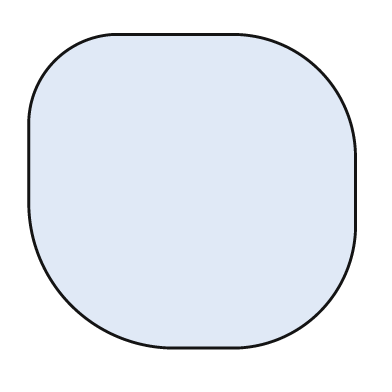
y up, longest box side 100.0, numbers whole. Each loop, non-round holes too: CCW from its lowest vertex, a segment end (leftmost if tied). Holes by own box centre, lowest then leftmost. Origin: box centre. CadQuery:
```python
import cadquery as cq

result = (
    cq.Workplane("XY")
    .moveTo(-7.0, -48.0)
    .lineTo(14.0, -48.0)
    .threePointArc((39.0, -37.0), (50.0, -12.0))
    .lineTo(50.0, 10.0)
    .threePointArc((39.0, 37.0), (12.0, 48.0))
    .lineTo(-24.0, 48.0)
    .threePointArc((-42.0, 40.0), (-50.0, 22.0))
    .lineTo(-50.0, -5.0)
    .threePointArc((-37.0, -35.0), (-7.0, -48.0))
    .close()
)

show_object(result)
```